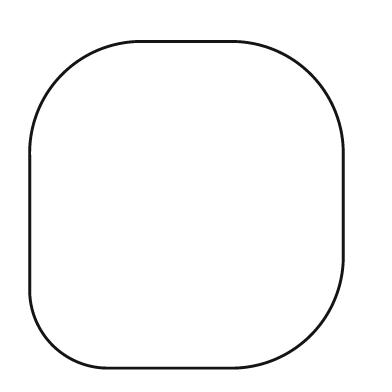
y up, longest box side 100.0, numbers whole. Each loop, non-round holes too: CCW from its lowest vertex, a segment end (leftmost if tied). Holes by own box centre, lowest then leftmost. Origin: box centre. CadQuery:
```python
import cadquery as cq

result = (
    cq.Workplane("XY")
    .moveTo(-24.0, -50.0)
    .lineTo(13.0, -50.0)
    .threePointArc((38.0, -40.0), (48.0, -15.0))
    .lineTo(48.0, 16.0)
    .threePointArc((38.0, 40.0), (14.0, 50.0))
    .lineTo(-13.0, 50.0)
    .threePointArc((-38.0, 40.0), (-48.0, 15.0))
    .lineTo(-48.0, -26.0)
    .threePointArc((-41.0, -43.0), (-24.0, -50.0))
    .close()
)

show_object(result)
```